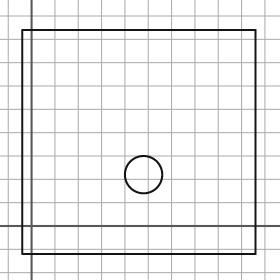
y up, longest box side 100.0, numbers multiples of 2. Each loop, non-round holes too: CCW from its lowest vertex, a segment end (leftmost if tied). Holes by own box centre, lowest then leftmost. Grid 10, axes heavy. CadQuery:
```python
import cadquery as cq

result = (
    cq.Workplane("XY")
    .moveTo(-4.0, -12.0)
    .lineTo(96.0, -12.0)
    .lineTo(96.0, 84.0)
    .lineTo(-4.0, 84.0)
    .close()
    .moveTo(48.0, 22.0)
    .circle(8.0)
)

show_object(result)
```